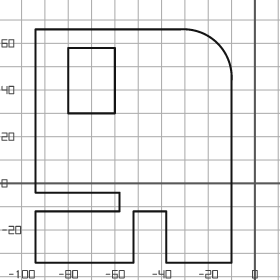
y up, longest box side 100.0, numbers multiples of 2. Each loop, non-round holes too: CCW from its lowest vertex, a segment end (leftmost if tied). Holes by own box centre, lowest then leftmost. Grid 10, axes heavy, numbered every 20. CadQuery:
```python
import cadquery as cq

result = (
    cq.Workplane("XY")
    .moveTo(-94.0, -34.0)
    .lineTo(-52.0, -34.0)
    .lineTo(-52.0, -12.0)
    .lineTo(-38.0, -12.0)
    .lineTo(-38.0, -34.0)
    .lineTo(-10.0, -34.0)
    .lineTo(-10.0, 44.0)
    .threePointArc((-16.0, 60.0), (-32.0, 66.0))
    .lineTo(-94.0, 66.0)
    .lineTo(-94.0, -4.0)
    .lineTo(-58.0, -4.0)
    .lineTo(-58.0, -12.0)
    .lineTo(-94.0, -12.0)
    .close()
    .moveTo(-80.0, 30.0)
    .lineTo(-60.0, 30.0)
    .lineTo(-60.0, 58.0)
    .lineTo(-80.0, 58.0)
    .close()
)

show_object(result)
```